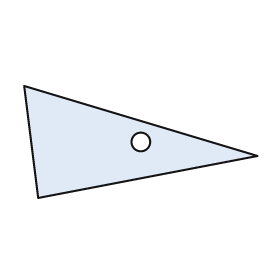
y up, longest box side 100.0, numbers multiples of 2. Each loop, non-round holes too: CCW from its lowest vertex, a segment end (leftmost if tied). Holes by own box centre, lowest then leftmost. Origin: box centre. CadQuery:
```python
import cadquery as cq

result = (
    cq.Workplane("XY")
    .moveTo(-44.0, -24.0)
    .lineTo(50.0, -6.0)
    .lineTo(-50.0, 24.0)
    .close()
    .moveTo(0.0, 0.0)
    .circle(4.0)
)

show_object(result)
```